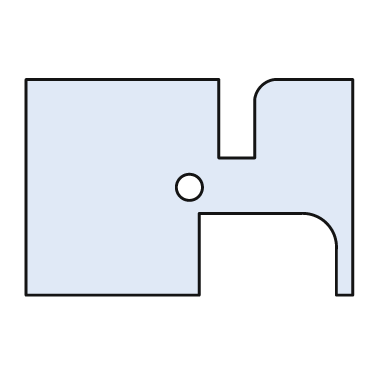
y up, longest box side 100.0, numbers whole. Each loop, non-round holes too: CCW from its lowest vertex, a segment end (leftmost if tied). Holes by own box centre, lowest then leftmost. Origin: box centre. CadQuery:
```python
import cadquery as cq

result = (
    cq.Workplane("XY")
    .moveTo(-50.0, -33.0)
    .lineTo(3.0, -33.0)
    .lineTo(3.0, -8.0)
    .lineTo(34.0, -8.0)
    .threePointArc((42.0, -11.0), (45.0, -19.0))
    .lineTo(45.0, -33.0)
    .lineTo(50.0, -33.0)
    .lineTo(50.0, 33.0)
    .lineTo(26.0, 33.0)
    .threePointArc((22.0, 31.0), (20.0, 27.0))
    .lineTo(20.0, 9.0)
    .lineTo(9.0, 9.0)
    .lineTo(9.0, 33.0)
    .lineTo(-50.0, 33.0)
    .close()
    .moveTo(0.0, 0.0)
    .circle(4.0)
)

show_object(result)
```